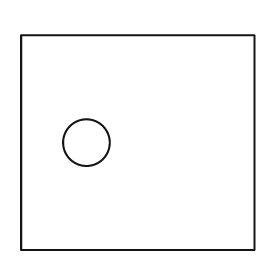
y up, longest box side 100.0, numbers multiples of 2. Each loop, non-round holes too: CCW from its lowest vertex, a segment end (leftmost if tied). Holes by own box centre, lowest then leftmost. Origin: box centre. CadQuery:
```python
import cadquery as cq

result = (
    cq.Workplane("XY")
    .moveTo(-50.0, -46.0)
    .lineTo(50.0, -46.0)
    .lineTo(50.0, 46.0)
    .lineTo(-50.0, 46.0)
    .close()
    .moveTo(-22.0, 0.0)
    .circle(10.0)
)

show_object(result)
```